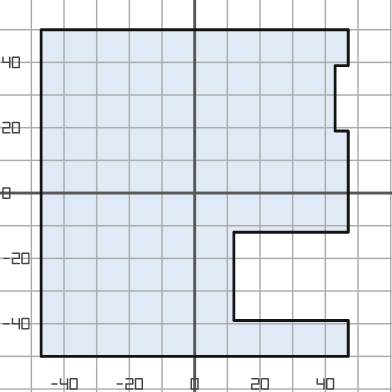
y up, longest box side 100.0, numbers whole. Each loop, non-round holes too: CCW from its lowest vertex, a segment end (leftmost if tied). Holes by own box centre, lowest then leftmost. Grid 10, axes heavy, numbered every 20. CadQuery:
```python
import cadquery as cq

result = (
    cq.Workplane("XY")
    .moveTo(-47.0, -50.0)
    .lineTo(47.0, -50.0)
    .lineTo(47.0, -39.0)
    .lineTo(12.0, -39.0)
    .lineTo(12.0, -12.0)
    .lineTo(47.0, -12.0)
    .lineTo(47.0, 19.0)
    .lineTo(43.0, 19.0)
    .lineTo(43.0, 39.0)
    .lineTo(47.0, 39.0)
    .lineTo(47.0, 50.0)
    .lineTo(-47.0, 50.0)
    .close()
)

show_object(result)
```